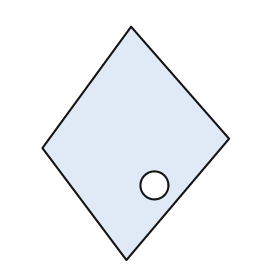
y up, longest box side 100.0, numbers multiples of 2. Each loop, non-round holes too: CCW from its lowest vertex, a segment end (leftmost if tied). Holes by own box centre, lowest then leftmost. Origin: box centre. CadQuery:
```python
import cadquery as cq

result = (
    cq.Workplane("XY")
    .moveTo(-4.0, -50.0)
    .lineTo(40.0, 2.0)
    .lineTo(-2.0, 50.0)
    .lineTo(-40.0, -2.0)
    .close()
    .moveTo(8.0, -18.0)
    .circle(6.0)
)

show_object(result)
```